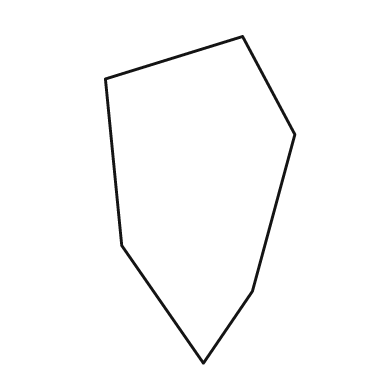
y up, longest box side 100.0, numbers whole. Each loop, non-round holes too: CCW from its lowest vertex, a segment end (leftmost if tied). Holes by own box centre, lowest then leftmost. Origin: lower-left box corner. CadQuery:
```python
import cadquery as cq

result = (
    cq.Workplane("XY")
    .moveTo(30.0, 0.0)
    .lineTo(45.0, 22.0)
    .lineTo(58.0, 70.0)
    .lineTo(42.0, 100.0)
    .lineTo(0.0, 87.0)
    .lineTo(5.0, 36.0)
    .close()
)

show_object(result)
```